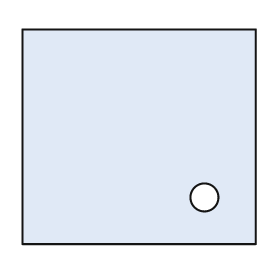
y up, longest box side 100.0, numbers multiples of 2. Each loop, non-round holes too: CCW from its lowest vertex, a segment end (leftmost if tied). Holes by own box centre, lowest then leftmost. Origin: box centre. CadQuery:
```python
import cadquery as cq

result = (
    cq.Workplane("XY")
    .moveTo(-50.0, -46.0)
    .lineTo(50.0, -46.0)
    .lineTo(50.0, 46.0)
    .lineTo(-50.0, 46.0)
    .close()
    .moveTo(28.0, -26.0)
    .circle(6.0)
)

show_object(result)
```